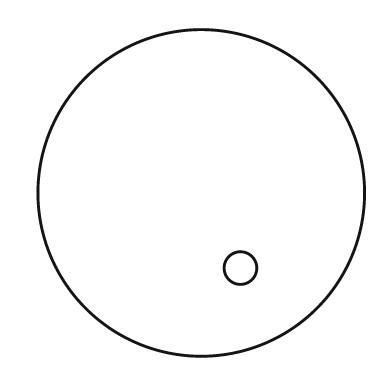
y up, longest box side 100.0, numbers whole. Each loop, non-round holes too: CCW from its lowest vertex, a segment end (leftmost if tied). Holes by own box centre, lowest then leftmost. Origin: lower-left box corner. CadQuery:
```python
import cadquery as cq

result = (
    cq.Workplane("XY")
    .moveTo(50.0, 50.0)
    .circle(50.0)
    .moveTo(62.0, 27.0)
    .circle(5.0)
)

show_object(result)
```